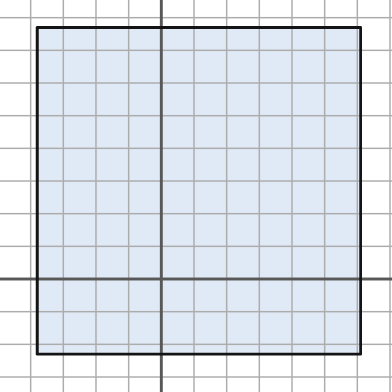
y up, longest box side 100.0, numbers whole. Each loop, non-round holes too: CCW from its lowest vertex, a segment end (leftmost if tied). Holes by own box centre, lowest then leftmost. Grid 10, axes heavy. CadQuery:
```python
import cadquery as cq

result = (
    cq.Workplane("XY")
    .moveTo(-38.0, -23.0)
    .lineTo(61.0, -23.0)
    .lineTo(61.0, 77.0)
    .lineTo(-38.0, 77.0)
    .close()
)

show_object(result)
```